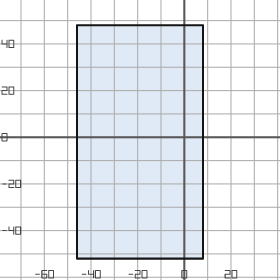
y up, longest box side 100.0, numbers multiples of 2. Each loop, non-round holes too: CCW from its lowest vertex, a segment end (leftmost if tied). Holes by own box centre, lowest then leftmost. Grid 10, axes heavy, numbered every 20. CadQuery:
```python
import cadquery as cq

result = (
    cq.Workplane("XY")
    .moveTo(-46.0, -52.0)
    .lineTo(8.0, -52.0)
    .lineTo(8.0, 48.0)
    .lineTo(-46.0, 48.0)
    .close()
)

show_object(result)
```